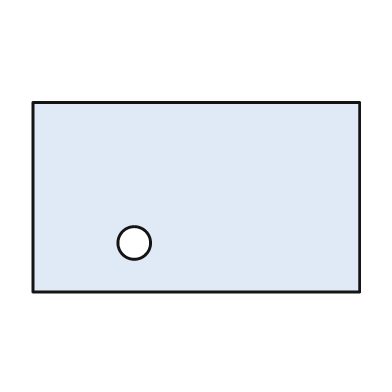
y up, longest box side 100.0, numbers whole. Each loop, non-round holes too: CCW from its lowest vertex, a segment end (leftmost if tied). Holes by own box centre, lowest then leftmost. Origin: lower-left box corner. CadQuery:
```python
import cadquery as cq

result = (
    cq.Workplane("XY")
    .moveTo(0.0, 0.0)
    .lineTo(100.0, 0.0)
    .lineTo(100.0, 58.0)
    .lineTo(0.0, 58.0)
    .close()
    .moveTo(31.0, 15.0)
    .circle(5.0)
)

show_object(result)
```